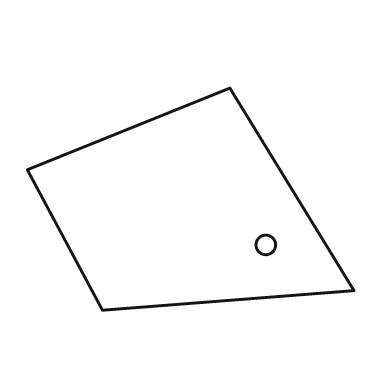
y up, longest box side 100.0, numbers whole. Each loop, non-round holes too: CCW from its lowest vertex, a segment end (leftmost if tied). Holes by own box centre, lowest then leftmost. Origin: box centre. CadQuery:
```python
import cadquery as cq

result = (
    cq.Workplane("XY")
    .moveTo(-27.0, -34.0)
    .lineTo(50.0, -28.0)
    .lineTo(12.0, 34.0)
    .lineTo(-50.0, 9.0)
    .close()
    .moveTo(23.0, -14.0)
    .circle(3.0)
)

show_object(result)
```